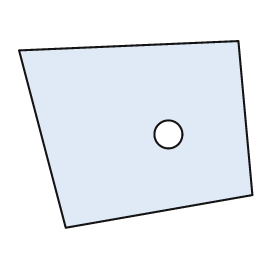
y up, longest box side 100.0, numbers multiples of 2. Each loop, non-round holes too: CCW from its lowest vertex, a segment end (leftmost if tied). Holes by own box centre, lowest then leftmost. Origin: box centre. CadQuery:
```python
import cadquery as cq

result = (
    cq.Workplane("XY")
    .moveTo(-30.0, -40.0)
    .lineTo(50.0, -26.0)
    .lineTo(44.0, 40.0)
    .lineTo(-50.0, 36.0)
    .close()
    .moveTo(14.0, 0.0)
    .circle(6.0)
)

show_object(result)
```